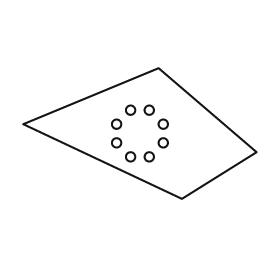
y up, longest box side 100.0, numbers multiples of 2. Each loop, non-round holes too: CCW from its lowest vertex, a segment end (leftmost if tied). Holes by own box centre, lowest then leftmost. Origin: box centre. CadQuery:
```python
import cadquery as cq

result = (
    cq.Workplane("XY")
    .moveTo(18.0, -28.0)
    .lineTo(50.0, -8.0)
    .lineTo(8.0, 28.0)
    .lineTo(-50.0, 4.0)
    .close()
    .moveTo(-4.0, -10.0)
    .circle(2.0)
    .moveTo(4.0, -10.0)
    .circle(2.0)
    .moveTo(-10.0, -4.0)
    .circle(2.0)
    .moveTo(10.0, -4.0)
    .circle(2.0)
    .moveTo(-10.0, 4.0)
    .circle(2.0)
    .moveTo(10.0, 4.0)
    .circle(2.0)
    .moveTo(-4.0, 10.0)
    .circle(2.0)
    .moveTo(4.0, 10.0)
    .circle(2.0)
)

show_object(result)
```